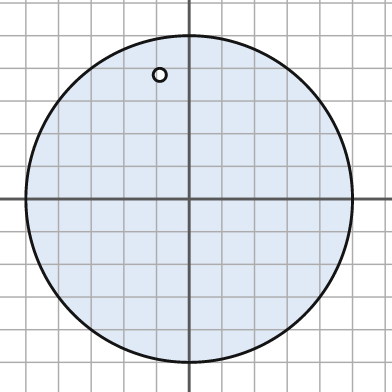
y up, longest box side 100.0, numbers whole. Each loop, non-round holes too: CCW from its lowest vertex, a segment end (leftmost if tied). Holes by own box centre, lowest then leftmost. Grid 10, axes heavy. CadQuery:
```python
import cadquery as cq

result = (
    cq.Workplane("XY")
    .moveTo(0.0, 0.0)
    .circle(50.0)
    .moveTo(-9.0, 38.0)
    .circle(2.0)
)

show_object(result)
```